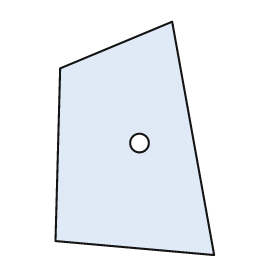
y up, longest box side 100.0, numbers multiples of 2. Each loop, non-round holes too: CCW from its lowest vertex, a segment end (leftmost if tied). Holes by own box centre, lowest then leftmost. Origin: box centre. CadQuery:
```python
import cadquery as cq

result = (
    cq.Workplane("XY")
    .moveTo(34.0, -50.0)
    .lineTo(16.0, 50.0)
    .lineTo(-32.0, 30.0)
    .lineTo(-34.0, -44.0)
    .close()
    .moveTo(2.0, -2.0)
    .circle(4.0)
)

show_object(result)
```